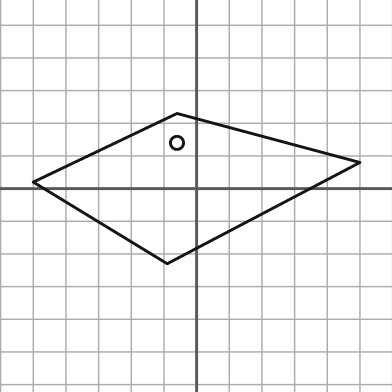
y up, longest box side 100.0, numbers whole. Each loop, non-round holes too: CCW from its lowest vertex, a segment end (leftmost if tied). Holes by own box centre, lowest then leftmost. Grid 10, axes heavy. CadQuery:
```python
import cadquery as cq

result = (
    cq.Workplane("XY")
    .moveTo(-9.0, -23.0)
    .lineTo(50.0, 8.0)
    .lineTo(-6.0, 23.0)
    .lineTo(-50.0, 2.0)
    .close()
    .moveTo(-6.0, 14.0)
    .circle(2.0)
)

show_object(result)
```